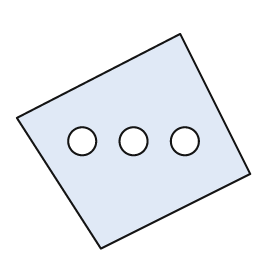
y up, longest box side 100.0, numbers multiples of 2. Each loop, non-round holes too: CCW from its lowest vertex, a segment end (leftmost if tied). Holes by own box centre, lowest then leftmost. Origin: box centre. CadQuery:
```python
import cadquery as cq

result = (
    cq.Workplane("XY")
    .moveTo(-14.0, -46.0)
    .lineTo(50.0, -14.0)
    .lineTo(20.0, 46.0)
    .lineTo(-50.0, 10.0)
    .close()
    .moveTo(-22.0, 0.0)
    .circle(6.0)
    .moveTo(0.0, 0.0)
    .circle(6.0)
    .moveTo(22.0, 0.0)
    .circle(6.0)
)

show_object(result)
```